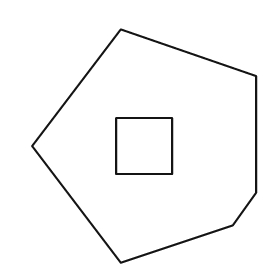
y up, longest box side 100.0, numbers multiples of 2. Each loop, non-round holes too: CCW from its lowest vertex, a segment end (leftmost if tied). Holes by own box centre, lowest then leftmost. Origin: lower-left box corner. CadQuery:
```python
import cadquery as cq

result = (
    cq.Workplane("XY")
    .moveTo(38.0, 0.0)
    .lineTo(86.0, 16.0)
    .lineTo(96.0, 30.0)
    .lineTo(96.0, 80.0)
    .lineTo(38.0, 100.0)
    .lineTo(0.0, 50.0)
    .close()
    .moveTo(36.0, 38.0)
    .lineTo(60.0, 38.0)
    .lineTo(60.0, 62.0)
    .lineTo(36.0, 62.0)
    .close()
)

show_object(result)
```